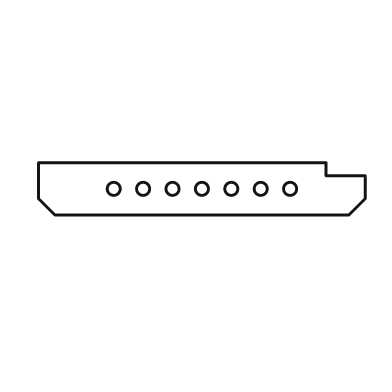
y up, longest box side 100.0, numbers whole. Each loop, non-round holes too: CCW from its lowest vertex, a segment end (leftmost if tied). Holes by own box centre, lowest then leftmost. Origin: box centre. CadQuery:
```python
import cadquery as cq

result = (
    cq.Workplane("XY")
    .moveTo(-45.0, -8.0)
    .lineTo(45.0, -8.0)
    .lineTo(50.0, -3.0)
    .lineTo(50.0, 4.0)
    .lineTo(38.0, 4.0)
    .lineTo(38.0, 8.0)
    .lineTo(-50.0, 8.0)
    .lineTo(-50.0, -3.0)
    .close()
    .moveTo(-27.0, 0.0)
    .circle(2.0)
    .moveTo(-18.0, 0.0)
    .circle(2.0)
    .moveTo(-9.0, 0.0)
    .circle(2.0)
    .moveTo(0.0, 0.0)
    .circle(2.0)
    .moveTo(9.0, 0.0)
    .circle(2.0)
    .moveTo(18.0, 0.0)
    .circle(2.0)
    .moveTo(27.0, 0.0)
    .circle(2.0)
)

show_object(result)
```